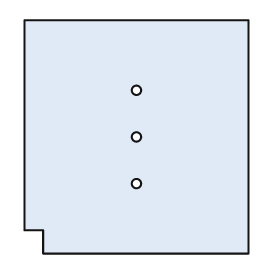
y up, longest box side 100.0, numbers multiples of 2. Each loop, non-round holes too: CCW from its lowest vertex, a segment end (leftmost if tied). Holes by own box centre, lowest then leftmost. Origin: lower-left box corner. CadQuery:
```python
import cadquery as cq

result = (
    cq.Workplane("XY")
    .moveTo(8.0, 0.0)
    .lineTo(96.0, 0.0)
    .lineTo(96.0, 100.0)
    .lineTo(0.0, 100.0)
    .lineTo(0.0, 10.0)
    .lineTo(8.0, 10.0)
    .close()
    .moveTo(48.0, 30.0)
    .circle(2.0)
    .moveTo(48.0, 50.0)
    .circle(2.0)
    .moveTo(48.0, 70.0)
    .circle(2.0)
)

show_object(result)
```